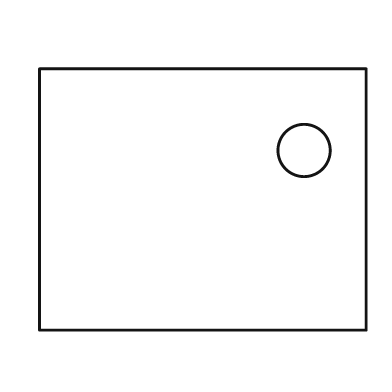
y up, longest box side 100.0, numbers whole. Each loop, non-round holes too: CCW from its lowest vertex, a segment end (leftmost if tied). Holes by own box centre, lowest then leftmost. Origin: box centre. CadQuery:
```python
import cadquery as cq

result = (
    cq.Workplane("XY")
    .moveTo(-50.0, -40.0)
    .lineTo(50.0, -40.0)
    .lineTo(50.0, 40.0)
    .lineTo(-50.0, 40.0)
    .close()
    .moveTo(31.0, 15.0)
    .circle(8.0)
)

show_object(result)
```